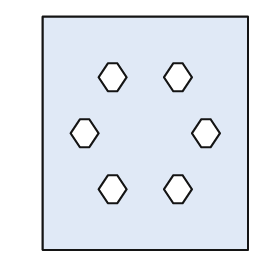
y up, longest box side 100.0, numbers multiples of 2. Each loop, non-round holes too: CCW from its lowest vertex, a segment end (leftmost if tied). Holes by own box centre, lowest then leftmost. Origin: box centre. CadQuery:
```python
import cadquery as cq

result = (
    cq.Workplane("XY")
    .moveTo(-44.0, -50.0)
    .lineTo(44.0, -50.0)
    .lineTo(44.0, 50.0)
    .lineTo(-44.0, 50.0)
    .close()
    .moveTo(-16.0, -30.0)
    .lineTo(-12.0, -30.0)
    .lineTo(-8.0, -24.0)
    .lineTo(-12.0, -18.0)
    .lineTo(-16.0, -18.0)
    .lineTo(-20.0, -24.0)
    .close()
    .moveTo(12.0, -30.0)
    .lineTo(16.0, -30.0)
    .lineTo(20.0, -24.0)
    .lineTo(16.0, -18.0)
    .lineTo(12.0, -18.0)
    .lineTo(8.0, -24.0)
    .close()
    .moveTo(-28.0, -6.0)
    .lineTo(-24.0, -6.0)
    .lineTo(-20.0, 0.0)
    .lineTo(-24.0, 6.0)
    .lineTo(-28.0, 6.0)
    .lineTo(-32.0, 0.0)
    .close()
    .moveTo(24.0, -6.0)
    .lineTo(28.0, -6.0)
    .lineTo(32.0, 0.0)
    .lineTo(28.0, 6.0)
    .lineTo(24.0, 6.0)
    .lineTo(20.0, 0.0)
    .close()
    .moveTo(-16.0, 18.0)
    .lineTo(-12.0, 18.0)
    .lineTo(-8.0, 24.0)
    .lineTo(-12.0, 30.0)
    .lineTo(-16.0, 30.0)
    .lineTo(-20.0, 24.0)
    .close()
    .moveTo(12.0, 18.0)
    .lineTo(16.0, 18.0)
    .lineTo(20.0, 24.0)
    .lineTo(16.0, 30.0)
    .lineTo(12.0, 30.0)
    .lineTo(8.0, 24.0)
    .close()
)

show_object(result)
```